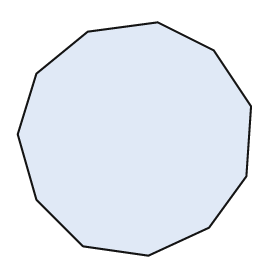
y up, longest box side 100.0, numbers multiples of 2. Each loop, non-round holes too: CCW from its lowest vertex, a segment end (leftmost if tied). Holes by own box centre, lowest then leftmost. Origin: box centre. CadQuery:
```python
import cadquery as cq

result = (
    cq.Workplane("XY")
    .moveTo(6.0, -50.0)
    .lineTo(32.0, -38.0)
    .lineTo(48.0, -16.0)
    .lineTo(50.0, 14.0)
    .lineTo(34.0, 38.0)
    .lineTo(10.0, 50.0)
    .lineTo(-20.0, 46.0)
    .lineTo(-42.0, 28.0)
    .lineTo(-50.0, 2.0)
    .lineTo(-42.0, -26.0)
    .lineTo(-22.0, -46.0)
    .close()
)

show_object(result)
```